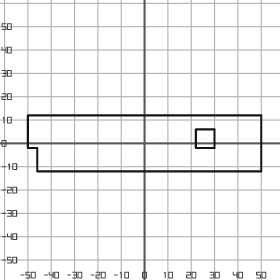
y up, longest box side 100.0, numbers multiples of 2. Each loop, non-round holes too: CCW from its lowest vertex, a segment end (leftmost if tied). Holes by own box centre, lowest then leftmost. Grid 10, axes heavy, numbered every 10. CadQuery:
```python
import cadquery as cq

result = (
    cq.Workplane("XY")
    .moveTo(-46.0, -12.0)
    .lineTo(50.0, -12.0)
    .lineTo(50.0, 12.0)
    .lineTo(-50.0, 12.0)
    .lineTo(-50.0, -2.0)
    .lineTo(-46.0, -2.0)
    .close()
    .moveTo(22.0, -2.0)
    .lineTo(30.0, -2.0)
    .lineTo(30.0, 6.0)
    .lineTo(22.0, 6.0)
    .close()
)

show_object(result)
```